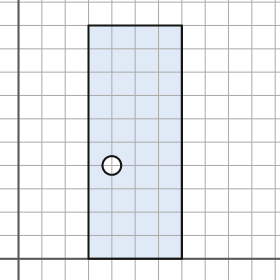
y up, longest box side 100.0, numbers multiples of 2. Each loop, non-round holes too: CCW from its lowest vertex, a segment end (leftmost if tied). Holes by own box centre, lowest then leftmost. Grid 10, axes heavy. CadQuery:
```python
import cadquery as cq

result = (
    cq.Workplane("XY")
    .moveTo(30.0, 0.0)
    .lineTo(70.0, 0.0)
    .lineTo(70.0, 100.0)
    .lineTo(30.0, 100.0)
    .close()
    .moveTo(40.0, 40.0)
    .circle(4.0)
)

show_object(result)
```